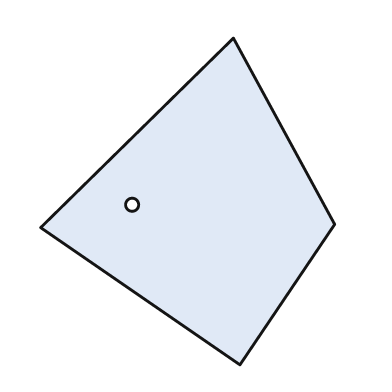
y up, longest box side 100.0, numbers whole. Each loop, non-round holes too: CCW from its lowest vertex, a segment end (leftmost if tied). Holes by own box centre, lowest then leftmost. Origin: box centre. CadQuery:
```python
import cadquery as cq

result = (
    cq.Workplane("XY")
    .moveTo(16.0, -50.0)
    .lineTo(45.0, -7.0)
    .lineTo(14.0, 50.0)
    .lineTo(-45.0, -8.0)
    .close()
    .moveTo(-17.0, -1.0)
    .circle(2.0)
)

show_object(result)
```